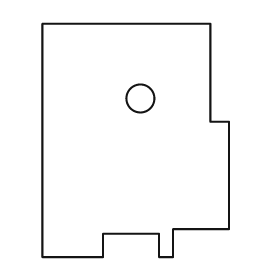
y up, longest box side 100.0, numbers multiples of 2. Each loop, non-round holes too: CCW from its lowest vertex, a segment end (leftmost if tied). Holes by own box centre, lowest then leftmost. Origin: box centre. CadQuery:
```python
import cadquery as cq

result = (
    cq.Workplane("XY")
    .moveTo(-40.0, -50.0)
    .lineTo(-14.0, -50.0)
    .lineTo(-14.0, -40.0)
    .lineTo(10.0, -40.0)
    .lineTo(10.0, -50.0)
    .lineTo(16.0, -50.0)
    .lineTo(16.0, -38.0)
    .lineTo(40.0, -38.0)
    .lineTo(40.0, 8.0)
    .lineTo(32.0, 8.0)
    .lineTo(32.0, 50.0)
    .lineTo(-40.0, 50.0)
    .close()
    .moveTo(2.0, 18.0)
    .circle(6.0)
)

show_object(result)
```